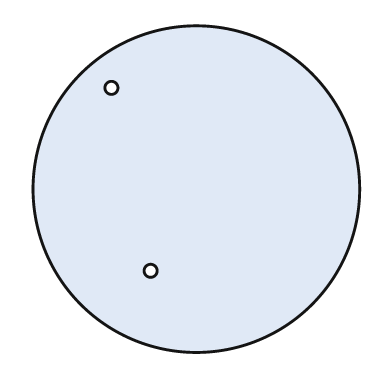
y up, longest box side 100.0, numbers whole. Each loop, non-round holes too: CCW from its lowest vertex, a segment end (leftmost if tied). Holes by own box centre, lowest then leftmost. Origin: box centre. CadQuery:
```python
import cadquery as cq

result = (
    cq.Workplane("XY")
    .moveTo(0.0, 0.0)
    .circle(50.0)
    .moveTo(-14.0, -25.0)
    .circle(2.0)
    .moveTo(-26.0, 31.0)
    .circle(2.0)
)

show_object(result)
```